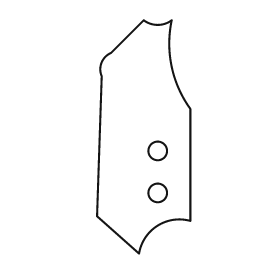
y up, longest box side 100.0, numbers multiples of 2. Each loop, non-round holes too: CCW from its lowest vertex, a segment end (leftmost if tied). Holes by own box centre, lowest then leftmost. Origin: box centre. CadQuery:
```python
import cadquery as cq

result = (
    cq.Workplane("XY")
    .moveTo(-2.0, -50.0)
    .threePointArc((6.0, -38.0), (20.0, -36.0))
    .lineTo(20.0, 12.0)
    .threePointArc((12.0, 30.0), (12.0, 50.0))
    .threePointArc((6.0, 48.0), (0.0, 50.0))
    .lineTo(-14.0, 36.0)
    .threePointArc((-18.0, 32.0), (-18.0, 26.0))
    .lineTo(-20.0, -34.0)
    .close()
    .moveTo(6.0, -24.0)
    .circle(4.0)
    .moveTo(6.0, -6.0)
    .circle(4.0)
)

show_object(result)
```